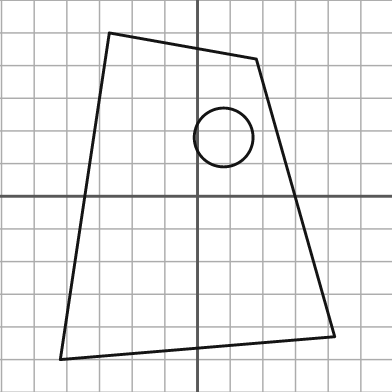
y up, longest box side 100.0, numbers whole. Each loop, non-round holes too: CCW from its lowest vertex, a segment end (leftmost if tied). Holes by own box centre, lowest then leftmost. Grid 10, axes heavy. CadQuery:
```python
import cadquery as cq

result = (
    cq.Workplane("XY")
    .moveTo(-42.0, -50.0)
    .lineTo(42.0, -43.0)
    .lineTo(18.0, 42.0)
    .lineTo(-27.0, 50.0)
    .close()
    .moveTo(8.0, 18.0)
    .circle(9.0)
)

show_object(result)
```